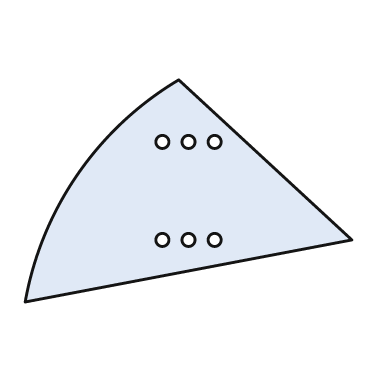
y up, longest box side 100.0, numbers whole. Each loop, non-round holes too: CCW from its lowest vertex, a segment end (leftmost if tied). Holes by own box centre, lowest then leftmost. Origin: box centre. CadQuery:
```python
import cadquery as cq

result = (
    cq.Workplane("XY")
    .moveTo(-50.0, -34.0)
    .lineTo(50.0, -15.0)
    .lineTo(-3.0, 34.0)
    .threePointArc((-34.0, 5.0), (-50.0, -34.0))
    .close()
    .moveTo(-8.0, -15.0)
    .circle(2.0)
    .moveTo(0.0, -15.0)
    .circle(2.0)
    .moveTo(8.0, -15.0)
    .circle(2.0)
    .moveTo(-8.0, 15.0)
    .circle(2.0)
    .moveTo(0.0, 15.0)
    .circle(2.0)
    .moveTo(8.0, 15.0)
    .circle(2.0)
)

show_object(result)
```